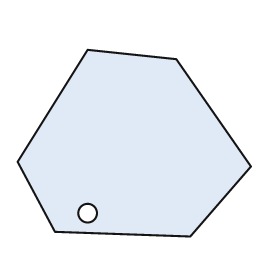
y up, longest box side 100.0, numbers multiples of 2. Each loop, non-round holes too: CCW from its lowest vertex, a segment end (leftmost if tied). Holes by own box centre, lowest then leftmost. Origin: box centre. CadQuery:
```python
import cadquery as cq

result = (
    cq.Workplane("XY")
    .moveTo(24.0, -40.0)
    .lineTo(50.0, -10.0)
    .lineTo(18.0, 36.0)
    .lineTo(-20.0, 40.0)
    .lineTo(-50.0, -8.0)
    .lineTo(-34.0, -38.0)
    .close()
    .moveTo(-20.0, -30.0)
    .circle(4.0)
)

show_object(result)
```